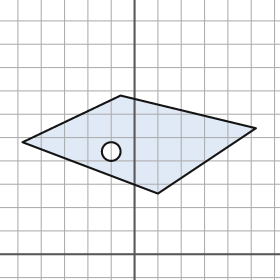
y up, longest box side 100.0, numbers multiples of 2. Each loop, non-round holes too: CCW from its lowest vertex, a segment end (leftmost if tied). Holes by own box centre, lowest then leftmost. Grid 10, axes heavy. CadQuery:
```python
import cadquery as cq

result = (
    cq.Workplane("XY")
    .moveTo(10.0, 26.0)
    .lineTo(52.0, 54.0)
    .lineTo(-6.0, 68.0)
    .lineTo(-48.0, 48.0)
    .close()
    .moveTo(-10.0, 44.0)
    .circle(4.0)
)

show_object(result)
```